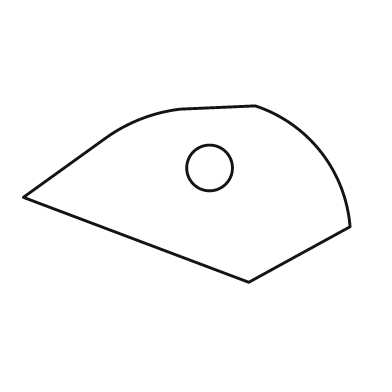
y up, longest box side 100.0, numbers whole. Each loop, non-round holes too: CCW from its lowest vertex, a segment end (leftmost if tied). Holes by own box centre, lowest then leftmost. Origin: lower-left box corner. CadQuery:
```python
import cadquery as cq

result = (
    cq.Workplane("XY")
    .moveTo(69.0, 0.0)
    .lineTo(100.0, 17.0)
    .threePointArc((91.0, 40.0), (71.0, 54.0))
    .lineTo(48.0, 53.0)
    .threePointArc((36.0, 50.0), (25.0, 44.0))
    .lineTo(0.0, 26.0)
    .close()
    .moveTo(57.0, 35.0)
    .circle(7.0)
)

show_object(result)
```